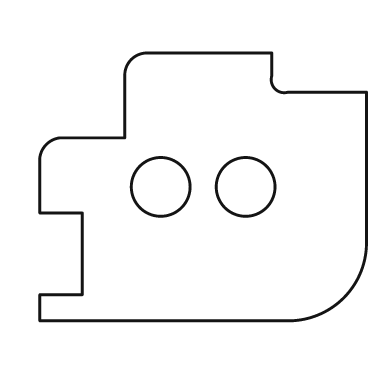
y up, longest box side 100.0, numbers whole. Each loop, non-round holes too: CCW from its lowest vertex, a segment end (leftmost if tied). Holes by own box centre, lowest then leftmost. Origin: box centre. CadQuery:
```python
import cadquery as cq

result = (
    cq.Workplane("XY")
    .moveTo(-50.0, -41.0)
    .lineTo(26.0, -41.0)
    .threePointArc((43.0, -34.0), (50.0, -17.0))
    .lineTo(50.0, 29.0)
    .lineTo(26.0, 29.0)
    .threePointArc((22.0, 30.0), (21.0, 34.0))
    .lineTo(21.0, 41.0)
    .lineTo(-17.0, 41.0)
    .threePointArc((-22.0, 39.0), (-24.0, 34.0))
    .lineTo(-24.0, 15.0)
    .lineTo(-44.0, 15.0)
    .threePointArc((-48.0, 13.0), (-50.0, 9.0))
    .lineTo(-50.0, -8.0)
    .lineTo(-37.0, -8.0)
    .lineTo(-37.0, -33.0)
    .lineTo(-50.0, -33.0)
    .close()
    .moveTo(-13.0, 0.0)
    .circle(9.0)
    .moveTo(13.0, 0.0)
    .circle(9.0)
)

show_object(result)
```